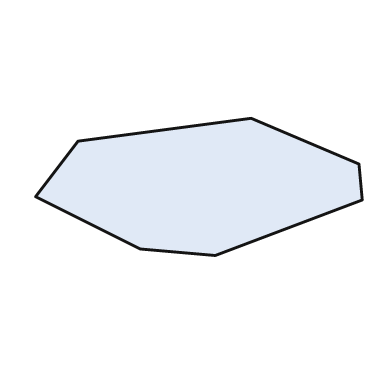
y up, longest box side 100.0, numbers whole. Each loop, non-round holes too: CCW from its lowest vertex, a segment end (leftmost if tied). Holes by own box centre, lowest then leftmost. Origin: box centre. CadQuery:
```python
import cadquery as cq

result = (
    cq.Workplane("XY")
    .moveTo(5.0, -21.0)
    .lineTo(50.0, -4.0)
    .lineTo(49.0, 7.0)
    .lineTo(16.0, 21.0)
    .lineTo(-37.0, 14.0)
    .lineTo(-50.0, -3.0)
    .lineTo(-18.0, -19.0)
    .close()
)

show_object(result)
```